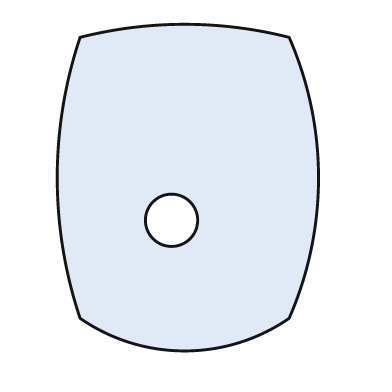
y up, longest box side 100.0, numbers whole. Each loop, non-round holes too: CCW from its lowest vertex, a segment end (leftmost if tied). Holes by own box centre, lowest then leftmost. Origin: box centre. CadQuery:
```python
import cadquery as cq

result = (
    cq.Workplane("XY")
    .moveTo(-33.0, -40.0)
    .threePointArc((-1.0, -50.0), (31.0, -40.0))
    .threePointArc((40.0, 3.0), (31.0, 46.0))
    .threePointArc((-1.0, 50.0), (-33.0, 46.0))
    .threePointArc((-40.0, 3.0), (-33.0, -40.0))
    .close()
    .moveTo(-5.0, -10.0)
    .circle(8.0)
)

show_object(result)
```